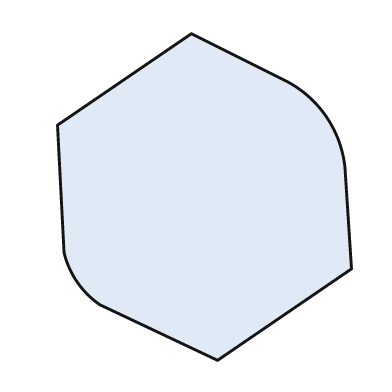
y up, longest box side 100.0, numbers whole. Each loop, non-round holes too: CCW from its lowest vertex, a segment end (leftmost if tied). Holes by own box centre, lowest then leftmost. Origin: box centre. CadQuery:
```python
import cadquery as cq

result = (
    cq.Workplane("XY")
    .moveTo(4.0, -50.0)
    .lineTo(45.0, -22.0)
    .lineTo(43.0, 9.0)
    .threePointArc((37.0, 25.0), (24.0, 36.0))
    .lineTo(-4.0, 50.0)
    .lineTo(-45.0, 22.0)
    .lineTo(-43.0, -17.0)
    .threePointArc((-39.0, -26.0), (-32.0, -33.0))
    .close()
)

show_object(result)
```